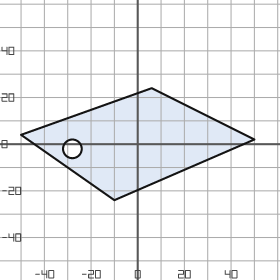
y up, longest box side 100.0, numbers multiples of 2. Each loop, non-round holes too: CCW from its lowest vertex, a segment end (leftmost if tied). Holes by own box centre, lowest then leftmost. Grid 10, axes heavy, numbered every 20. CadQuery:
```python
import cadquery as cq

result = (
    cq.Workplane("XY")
    .moveTo(-10.0, -24.0)
    .lineTo(50.0, 2.0)
    .lineTo(6.0, 24.0)
    .lineTo(-50.0, 4.0)
    .close()
    .moveTo(-28.0, -2.0)
    .circle(4.0)
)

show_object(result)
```